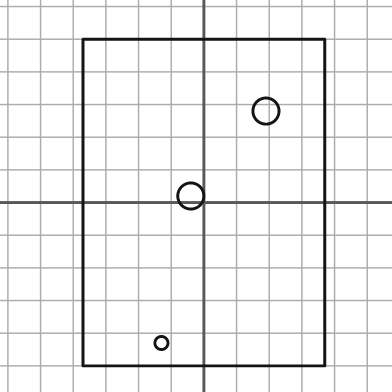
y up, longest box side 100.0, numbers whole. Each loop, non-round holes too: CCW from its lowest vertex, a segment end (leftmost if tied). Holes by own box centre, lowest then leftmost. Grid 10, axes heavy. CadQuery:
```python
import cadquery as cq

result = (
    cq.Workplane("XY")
    .moveTo(-37.0, -50.0)
    .lineTo(37.0, -50.0)
    .lineTo(37.0, 50.0)
    .lineTo(-37.0, 50.0)
    .close()
    .moveTo(-13.0, -43.0)
    .circle(2.0)
    .moveTo(-4.0, 2.0)
    .circle(4.0)
    .moveTo(19.0, 28.0)
    .circle(4.0)
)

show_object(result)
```